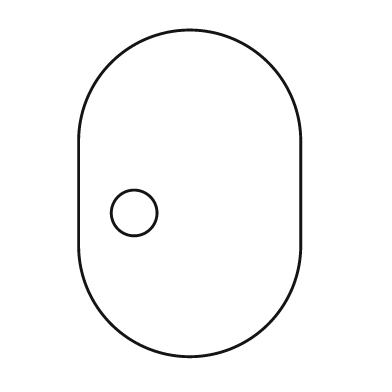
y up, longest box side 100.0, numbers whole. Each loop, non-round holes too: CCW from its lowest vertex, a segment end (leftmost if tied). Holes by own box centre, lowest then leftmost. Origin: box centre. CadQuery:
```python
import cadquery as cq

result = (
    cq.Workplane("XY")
    .moveTo(-34.0, -16.0)
    .threePointArc((0.0, -50.0), (34.0, -16.0))
    .lineTo(34.0, 16.0)
    .threePointArc((0.0, 50.0), (-34.0, 16.0))
    .close()
    .moveTo(-17.0, -6.0)
    .circle(7.0)
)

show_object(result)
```